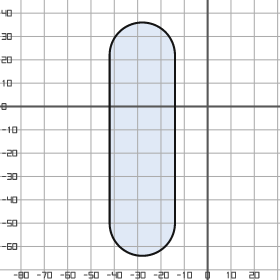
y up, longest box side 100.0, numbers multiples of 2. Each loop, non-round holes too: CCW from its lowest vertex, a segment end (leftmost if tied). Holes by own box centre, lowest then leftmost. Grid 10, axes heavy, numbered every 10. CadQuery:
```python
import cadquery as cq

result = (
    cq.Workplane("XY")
    .moveTo(-42.0, -50.0)
    .threePointArc((-28.0, -64.0), (-14.0, -50.0))
    .lineTo(-14.0, 22.0)
    .threePointArc((-28.0, 36.0), (-42.0, 22.0))
    .close()
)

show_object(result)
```